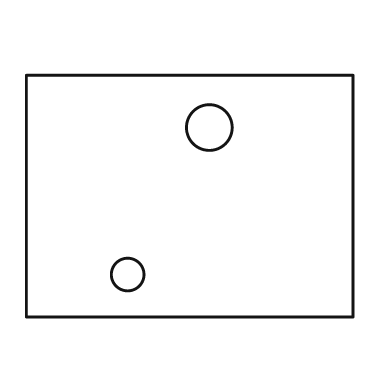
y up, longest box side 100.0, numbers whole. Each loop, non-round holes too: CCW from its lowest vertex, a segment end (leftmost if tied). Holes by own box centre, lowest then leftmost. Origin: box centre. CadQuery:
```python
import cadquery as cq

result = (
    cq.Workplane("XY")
    .moveTo(-50.0, -37.0)
    .lineTo(50.0, -37.0)
    .lineTo(50.0, 37.0)
    .lineTo(-50.0, 37.0)
    .close()
    .moveTo(-19.0, -24.0)
    .circle(5.0)
    .moveTo(6.0, 21.0)
    .circle(7.0)
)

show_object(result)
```